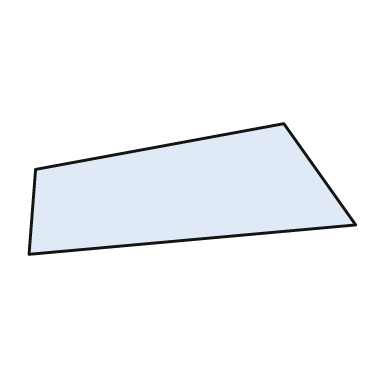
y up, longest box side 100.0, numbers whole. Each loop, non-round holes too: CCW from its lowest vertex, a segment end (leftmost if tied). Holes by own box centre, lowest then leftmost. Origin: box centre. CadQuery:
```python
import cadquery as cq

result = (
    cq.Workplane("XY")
    .moveTo(-50.0, -20.0)
    .lineTo(50.0, -11.0)
    .lineTo(28.0, 20.0)
    .lineTo(-48.0, 6.0)
    .close()
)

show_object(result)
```